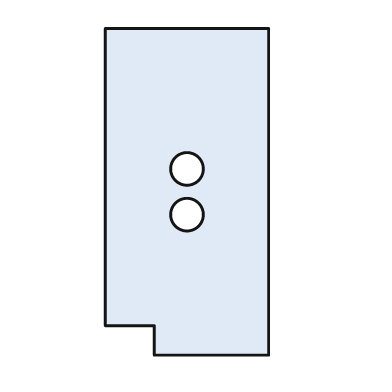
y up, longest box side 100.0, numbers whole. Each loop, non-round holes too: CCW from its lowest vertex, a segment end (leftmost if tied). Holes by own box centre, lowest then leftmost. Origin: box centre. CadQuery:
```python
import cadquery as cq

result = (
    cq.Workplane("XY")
    .moveTo(-10.0, -50.0)
    .lineTo(25.0, -50.0)
    .lineTo(25.0, 50.0)
    .lineTo(-25.0, 50.0)
    .lineTo(-25.0, -41.0)
    .lineTo(-10.0, -41.0)
    .close()
    .moveTo(0.0, -7.0)
    .circle(5.0)
    .moveTo(0.0, 7.0)
    .circle(5.0)
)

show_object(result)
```